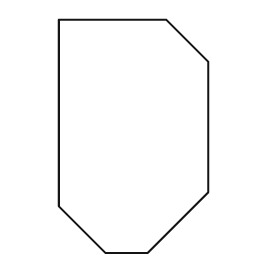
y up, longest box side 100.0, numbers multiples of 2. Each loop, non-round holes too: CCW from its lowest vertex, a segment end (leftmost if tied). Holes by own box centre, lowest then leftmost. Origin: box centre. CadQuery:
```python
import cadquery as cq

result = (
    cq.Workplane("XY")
    .moveTo(-12.0, -50.0)
    .lineTo(6.0, -50.0)
    .lineTo(32.0, -24.0)
    .lineTo(32.0, 32.0)
    .lineTo(14.0, 50.0)
    .lineTo(-32.0, 50.0)
    .lineTo(-32.0, -30.0)
    .close()
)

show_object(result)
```